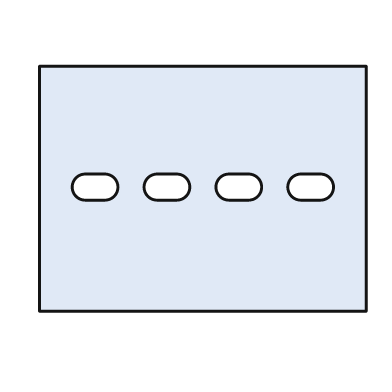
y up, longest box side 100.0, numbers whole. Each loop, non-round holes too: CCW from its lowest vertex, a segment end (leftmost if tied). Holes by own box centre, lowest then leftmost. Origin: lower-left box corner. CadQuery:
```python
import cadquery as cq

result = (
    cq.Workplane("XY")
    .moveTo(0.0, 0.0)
    .lineTo(100.0, 0.0)
    .lineTo(100.0, 75.0)
    .lineTo(0.0, 75.0)
    .close()
    .moveTo(14.0, 34.0)
    .lineTo(20.0, 34.0)
    .threePointArc((24.0, 38.0), (20.0, 42.0))
    .lineTo(14.0, 42.0)
    .threePointArc((10.0, 38.0), (14.0, 34.0))
    .close()
    .moveTo(36.0, 34.0)
    .lineTo(42.0, 34.0)
    .threePointArc((46.0, 38.0), (42.0, 42.0))
    .lineTo(36.0, 42.0)
    .threePointArc((32.0, 38.0), (36.0, 34.0))
    .close()
    .moveTo(58.0, 34.0)
    .lineTo(64.0, 34.0)
    .threePointArc((68.0, 38.0), (64.0, 42.0))
    .lineTo(58.0, 42.0)
    .threePointArc((54.0, 38.0), (58.0, 34.0))
    .close()
    .moveTo(80.0, 34.0)
    .lineTo(86.0, 34.0)
    .threePointArc((90.0, 38.0), (86.0, 42.0))
    .lineTo(80.0, 42.0)
    .threePointArc((76.0, 38.0), (80.0, 34.0))
    .close()
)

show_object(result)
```